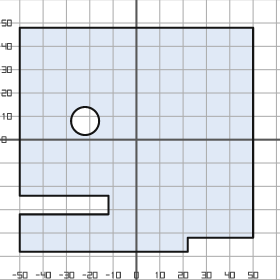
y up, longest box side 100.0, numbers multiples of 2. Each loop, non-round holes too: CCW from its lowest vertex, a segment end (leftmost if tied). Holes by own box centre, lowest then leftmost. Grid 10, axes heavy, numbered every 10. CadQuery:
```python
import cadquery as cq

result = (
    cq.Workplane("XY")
    .moveTo(-50.0, -48.0)
    .lineTo(22.0, -48.0)
    .lineTo(22.0, -42.0)
    .lineTo(50.0, -42.0)
    .lineTo(50.0, 48.0)
    .lineTo(-50.0, 48.0)
    .lineTo(-50.0, -24.0)
    .lineTo(-12.0, -24.0)
    .lineTo(-12.0, -32.0)
    .lineTo(-50.0, -32.0)
    .close()
    .moveTo(-22.0, 8.0)
    .circle(6.0)
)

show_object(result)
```